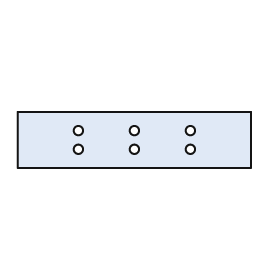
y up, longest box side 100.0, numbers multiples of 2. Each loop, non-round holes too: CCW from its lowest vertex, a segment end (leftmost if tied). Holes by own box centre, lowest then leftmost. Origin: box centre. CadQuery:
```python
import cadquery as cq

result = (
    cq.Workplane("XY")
    .moveTo(-50.0, -12.0)
    .lineTo(50.0, -12.0)
    .lineTo(50.0, 12.0)
    .lineTo(-50.0, 12.0)
    .close()
    .moveTo(-24.0, -4.0)
    .circle(2.0)
    .moveTo(0.0, -4.0)
    .circle(2.0)
    .moveTo(24.0, -4.0)
    .circle(2.0)
    .moveTo(-24.0, 4.0)
    .circle(2.0)
    .moveTo(0.0, 4.0)
    .circle(2.0)
    .moveTo(24.0, 4.0)
    .circle(2.0)
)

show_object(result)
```